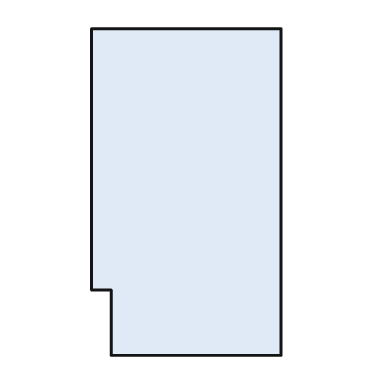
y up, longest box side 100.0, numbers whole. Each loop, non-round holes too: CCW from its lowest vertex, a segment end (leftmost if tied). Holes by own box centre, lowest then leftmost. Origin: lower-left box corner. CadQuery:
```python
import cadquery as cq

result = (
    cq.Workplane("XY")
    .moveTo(6.0, 0.0)
    .lineTo(58.0, 0.0)
    .lineTo(58.0, 100.0)
    .lineTo(0.0, 100.0)
    .lineTo(0.0, 20.0)
    .lineTo(6.0, 20.0)
    .close()
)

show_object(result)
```